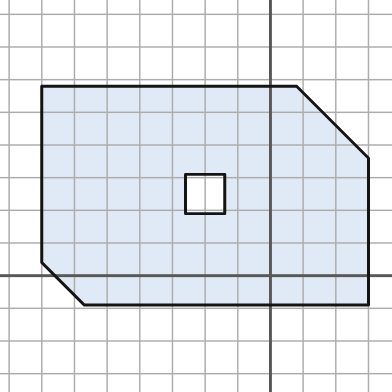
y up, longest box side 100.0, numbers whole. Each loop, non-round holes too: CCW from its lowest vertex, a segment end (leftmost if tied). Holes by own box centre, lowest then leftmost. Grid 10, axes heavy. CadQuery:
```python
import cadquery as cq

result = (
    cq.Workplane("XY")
    .moveTo(-57.0, -9.0)
    .lineTo(30.0, -9.0)
    .lineTo(30.0, 36.0)
    .lineTo(8.0, 58.0)
    .lineTo(-70.0, 58.0)
    .lineTo(-70.0, 4.0)
    .close()
    .moveTo(-26.0, 19.0)
    .lineTo(-14.0, 19.0)
    .lineTo(-14.0, 31.0)
    .lineTo(-26.0, 31.0)
    .close()
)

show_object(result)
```